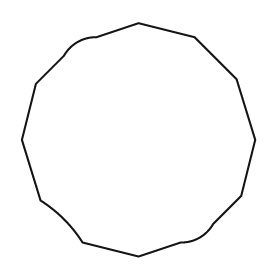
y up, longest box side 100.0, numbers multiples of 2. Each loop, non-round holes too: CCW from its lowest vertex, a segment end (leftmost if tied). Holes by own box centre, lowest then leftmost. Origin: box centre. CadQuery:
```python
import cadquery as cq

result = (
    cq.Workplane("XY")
    .moveTo(0.0, -50.0)
    .lineTo(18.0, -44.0)
    .threePointArc((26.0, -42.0), (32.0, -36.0))
    .lineTo(44.0, -24.0)
    .lineTo(50.0, 0.0)
    .lineTo(42.0, 26.0)
    .lineTo(24.0, 44.0)
    .lineTo(0.0, 50.0)
    .lineTo(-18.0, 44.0)
    .threePointArc((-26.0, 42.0), (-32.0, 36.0))
    .lineTo(-44.0, 24.0)
    .lineTo(-50.0, 0.0)
    .lineTo(-42.0, -26.0)
    .threePointArc((-32.0, -34.0), (-24.0, -44.0))
    .close()
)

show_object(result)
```